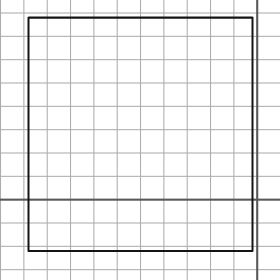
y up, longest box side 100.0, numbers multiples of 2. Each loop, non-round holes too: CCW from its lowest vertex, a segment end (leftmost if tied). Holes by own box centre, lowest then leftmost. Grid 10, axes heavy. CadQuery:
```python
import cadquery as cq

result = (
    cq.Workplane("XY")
    .moveTo(-98.0, -22.0)
    .lineTo(-2.0, -22.0)
    .lineTo(-2.0, 78.0)
    .lineTo(-98.0, 78.0)
    .close()
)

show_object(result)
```